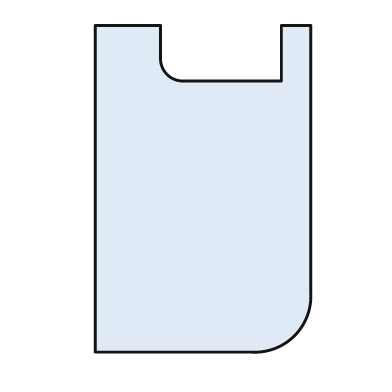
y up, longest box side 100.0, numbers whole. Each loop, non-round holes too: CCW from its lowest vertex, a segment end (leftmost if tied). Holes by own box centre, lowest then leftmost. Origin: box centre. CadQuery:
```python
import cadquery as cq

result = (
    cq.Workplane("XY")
    .moveTo(-33.0, -50.0)
    .lineTo(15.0, -50.0)
    .threePointArc((28.0, -45.0), (33.0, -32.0))
    .lineTo(33.0, 50.0)
    .lineTo(24.0, 50.0)
    .lineTo(24.0, 33.0)
    .lineTo(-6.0, 33.0)
    .threePointArc((-11.0, 35.0), (-13.0, 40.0))
    .lineTo(-13.0, 50.0)
    .lineTo(-33.0, 50.0)
    .close()
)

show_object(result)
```